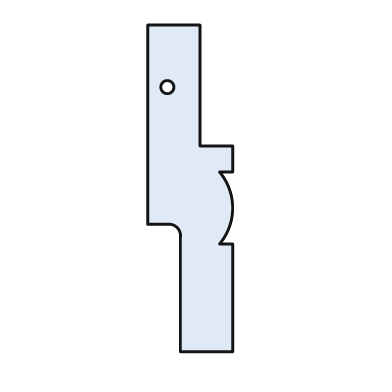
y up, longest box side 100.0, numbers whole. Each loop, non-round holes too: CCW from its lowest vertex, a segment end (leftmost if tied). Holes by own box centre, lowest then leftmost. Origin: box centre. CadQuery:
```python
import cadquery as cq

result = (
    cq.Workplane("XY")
    .moveTo(-3.0, -50.0)
    .lineTo(13.0, -50.0)
    .lineTo(13.0, -17.0)
    .lineTo(9.0, -17.0)
    .threePointArc((13.0, -6.0), (9.0, 5.0))
    .lineTo(13.0, 5.0)
    .lineTo(13.0, 13.0)
    .lineTo(3.0, 13.0)
    .lineTo(3.0, 50.0)
    .lineTo(-13.0, 50.0)
    .lineTo(-13.0, -11.0)
    .lineTo(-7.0, -11.0)
    .threePointArc((-4.0, -12.0), (-3.0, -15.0))
    .close()
    .moveTo(-7.0, 31.0)
    .circle(2.0)
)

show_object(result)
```